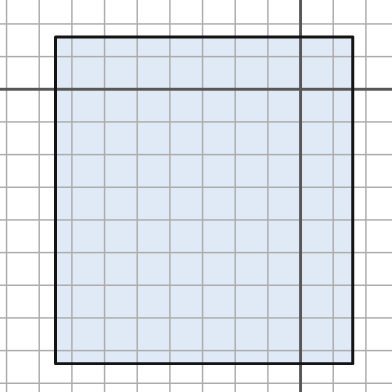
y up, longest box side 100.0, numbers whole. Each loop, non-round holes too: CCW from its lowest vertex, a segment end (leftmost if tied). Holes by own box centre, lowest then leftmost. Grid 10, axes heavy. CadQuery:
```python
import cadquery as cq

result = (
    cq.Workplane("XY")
    .moveTo(-75.0, -84.0)
    .lineTo(16.0, -84.0)
    .lineTo(16.0, 16.0)
    .lineTo(-75.0, 16.0)
    .close()
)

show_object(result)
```